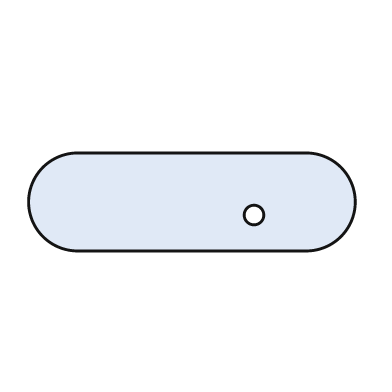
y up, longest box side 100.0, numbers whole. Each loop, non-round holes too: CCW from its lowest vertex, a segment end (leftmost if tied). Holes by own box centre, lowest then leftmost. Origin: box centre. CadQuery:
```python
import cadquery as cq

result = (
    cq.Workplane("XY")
    .moveTo(-35.0, -15.0)
    .lineTo(35.0, -15.0)
    .threePointArc((50.0, 0.0), (35.0, 15.0))
    .lineTo(-35.0, 15.0)
    .threePointArc((-50.0, 0.0), (-35.0, -15.0))
    .close()
    .moveTo(19.0, -4.0)
    .circle(3.0)
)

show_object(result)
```